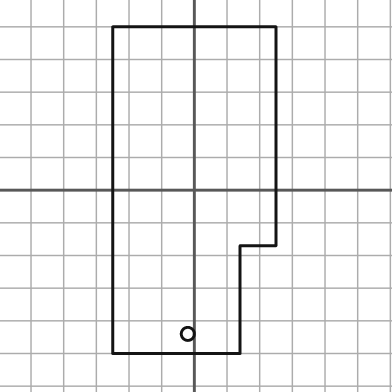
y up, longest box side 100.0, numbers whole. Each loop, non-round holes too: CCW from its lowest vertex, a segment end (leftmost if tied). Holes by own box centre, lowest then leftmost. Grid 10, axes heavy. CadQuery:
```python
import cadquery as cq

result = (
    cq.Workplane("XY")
    .moveTo(-25.0, -50.0)
    .lineTo(14.0, -50.0)
    .lineTo(14.0, -17.0)
    .lineTo(25.0, -17.0)
    .lineTo(25.0, 50.0)
    .lineTo(-25.0, 50.0)
    .close()
    .moveTo(-2.0, -44.0)
    .circle(2.0)
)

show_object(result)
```